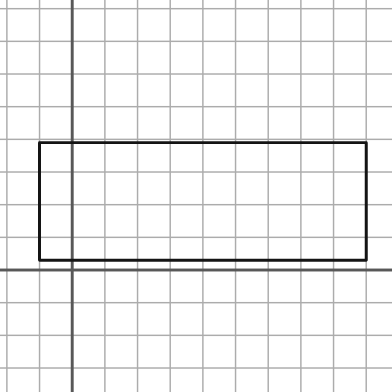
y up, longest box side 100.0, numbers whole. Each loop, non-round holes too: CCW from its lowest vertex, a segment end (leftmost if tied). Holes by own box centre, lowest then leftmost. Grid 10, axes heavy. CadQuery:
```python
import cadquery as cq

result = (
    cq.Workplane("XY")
    .moveTo(-10.0, 3.0)
    .lineTo(90.0, 3.0)
    .lineTo(90.0, 39.0)
    .lineTo(-10.0, 39.0)
    .close()
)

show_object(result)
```